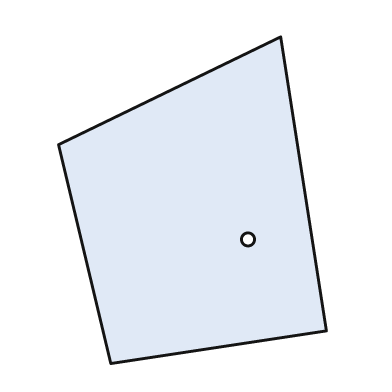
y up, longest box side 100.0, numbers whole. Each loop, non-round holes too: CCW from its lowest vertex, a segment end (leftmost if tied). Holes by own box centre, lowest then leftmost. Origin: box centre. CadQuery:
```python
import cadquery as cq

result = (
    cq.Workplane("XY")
    .moveTo(-25.0, -50.0)
    .lineTo(41.0, -40.0)
    .lineTo(27.0, 50.0)
    .lineTo(-41.0, 17.0)
    .close()
    .moveTo(17.0, -12.0)
    .circle(2.0)
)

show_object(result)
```